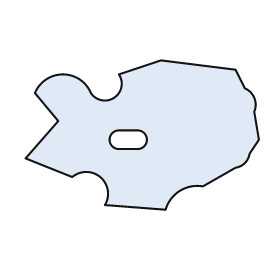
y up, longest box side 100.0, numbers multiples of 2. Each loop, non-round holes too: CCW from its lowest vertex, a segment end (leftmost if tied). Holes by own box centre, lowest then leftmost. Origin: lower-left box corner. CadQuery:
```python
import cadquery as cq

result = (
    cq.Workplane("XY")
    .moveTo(60.0, 0.0)
    .threePointArc((66.0, 8.0), (76.0, 10.0))
    .lineTo(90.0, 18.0)
    .threePointArc((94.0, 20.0), (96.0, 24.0))
    .lineTo(100.0, 30.0)
    .lineTo(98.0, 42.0)
    .threePointArc((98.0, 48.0), (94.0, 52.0))
    .lineTo(90.0, 60.0)
    .lineTo(58.0, 64.0)
    .lineTo(40.0, 58.0)
    .threePointArc((38.0, 48.0), (28.0, 50.0))
    .threePointArc((16.0, 58.0), (4.0, 50.0))
    .lineTo(14.0, 38.0)
    .lineTo(0.0, 22.0)
    .lineTo(20.0, 14.0)
    .threePointArc((32.0, 14.0), (34.0, 2.0))
    .close()
    .moveTo(40.0, 26.0)
    .lineTo(48.0, 26.0)
    .threePointArc((52.0, 30.0), (48.0, 34.0))
    .lineTo(40.0, 34.0)
    .threePointArc((36.0, 30.0), (40.0, 26.0))
    .close()
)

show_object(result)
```